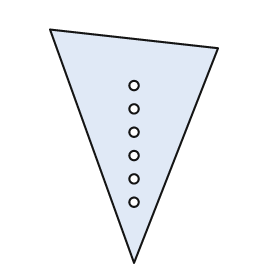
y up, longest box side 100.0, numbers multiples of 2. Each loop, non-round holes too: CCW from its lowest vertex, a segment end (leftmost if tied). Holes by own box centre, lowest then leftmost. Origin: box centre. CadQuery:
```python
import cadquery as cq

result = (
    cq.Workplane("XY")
    .moveTo(0.0, -50.0)
    .lineTo(36.0, 42.0)
    .lineTo(-36.0, 50.0)
    .close()
    .moveTo(0.0, -24.0)
    .circle(2.0)
    .moveTo(0.0, -14.0)
    .circle(2.0)
    .moveTo(0.0, -4.0)
    .circle(2.0)
    .moveTo(0.0, 6.0)
    .circle(2.0)
    .moveTo(0.0, 16.0)
    .circle(2.0)
    .moveTo(0.0, 26.0)
    .circle(2.0)
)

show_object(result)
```